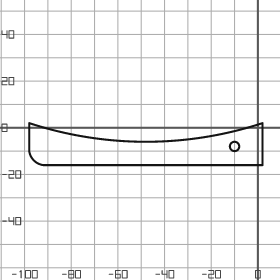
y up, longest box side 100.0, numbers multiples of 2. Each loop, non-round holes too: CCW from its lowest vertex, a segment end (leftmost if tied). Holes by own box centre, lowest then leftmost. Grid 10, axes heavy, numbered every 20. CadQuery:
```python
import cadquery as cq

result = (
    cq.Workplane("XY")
    .moveTo(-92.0, -16.0)
    .lineTo(2.0, -16.0)
    .lineTo(2.0, 2.0)
    .threePointArc((-48.0, -6.0), (-98.0, 2.0))
    .lineTo(-98.0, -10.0)
    .threePointArc((-96.0, -14.0), (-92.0, -16.0))
    .close()
    .moveTo(-10.0, -8.0)
    .circle(2.0)
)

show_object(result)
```